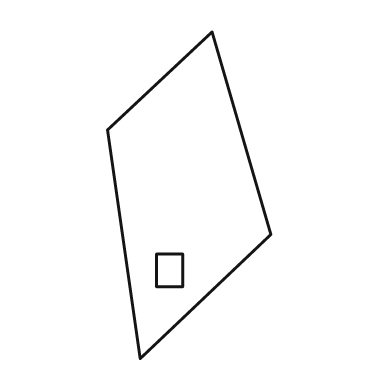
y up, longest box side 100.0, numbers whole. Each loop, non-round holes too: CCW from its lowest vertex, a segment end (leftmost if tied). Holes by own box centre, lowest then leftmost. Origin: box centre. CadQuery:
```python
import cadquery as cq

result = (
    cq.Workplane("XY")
    .moveTo(-15.0, -50.0)
    .lineTo(25.0, -12.0)
    .lineTo(7.0, 50.0)
    .lineTo(-25.0, 20.0)
    .close()
    .moveTo(-10.0, -28.0)
    .lineTo(-2.0, -28.0)
    .lineTo(-2.0, -18.0)
    .lineTo(-10.0, -18.0)
    .close()
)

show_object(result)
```